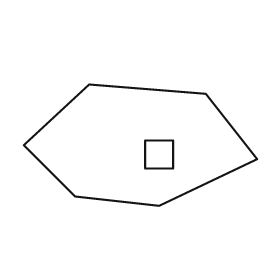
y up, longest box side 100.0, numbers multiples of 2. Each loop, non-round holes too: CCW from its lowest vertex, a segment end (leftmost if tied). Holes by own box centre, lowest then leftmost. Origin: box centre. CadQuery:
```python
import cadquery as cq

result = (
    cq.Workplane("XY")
    .moveTo(8.0, -26.0)
    .lineTo(50.0, -6.0)
    .lineTo(28.0, 22.0)
    .lineTo(-22.0, 26.0)
    .lineTo(-50.0, 0.0)
    .lineTo(-28.0, -22.0)
    .close()
    .moveTo(2.0, -10.0)
    .lineTo(14.0, -10.0)
    .lineTo(14.0, 2.0)
    .lineTo(2.0, 2.0)
    .close()
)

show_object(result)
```